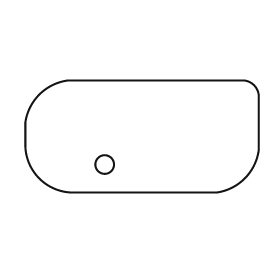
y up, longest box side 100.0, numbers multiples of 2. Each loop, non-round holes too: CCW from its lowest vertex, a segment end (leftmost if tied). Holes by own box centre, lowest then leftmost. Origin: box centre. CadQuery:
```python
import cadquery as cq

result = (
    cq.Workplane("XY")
    .moveTo(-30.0, -24.0)
    .lineTo(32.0, -24.0)
    .threePointArc((44.0, -18.0), (50.0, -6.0))
    .lineTo(50.0, 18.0)
    .threePointArc((48.0, 22.0), (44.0, 24.0))
    .lineTo(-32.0, 24.0)
    .threePointArc((-44.0, 18.0), (-50.0, 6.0))
    .lineTo(-50.0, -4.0)
    .threePointArc((-44.0, -18.0), (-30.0, -24.0))
    .close()
    .moveTo(-16.0, -12.0)
    .circle(4.0)
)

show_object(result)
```